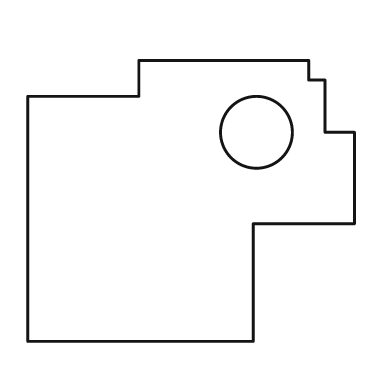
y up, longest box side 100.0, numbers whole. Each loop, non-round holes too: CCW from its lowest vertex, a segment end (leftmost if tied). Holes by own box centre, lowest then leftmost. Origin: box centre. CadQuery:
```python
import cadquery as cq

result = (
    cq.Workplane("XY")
    .moveTo(-50.0, -43.0)
    .lineTo(19.0, -43.0)
    .lineTo(19.0, -7.0)
    .lineTo(50.0, -7.0)
    .lineTo(50.0, 21.0)
    .lineTo(41.0, 21.0)
    .lineTo(41.0, 37.0)
    .lineTo(36.0, 37.0)
    .lineTo(36.0, 43.0)
    .lineTo(-16.0, 43.0)
    .lineTo(-16.0, 32.0)
    .lineTo(-50.0, 32.0)
    .close()
    .moveTo(20.0, 21.0)
    .circle(11.0)
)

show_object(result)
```